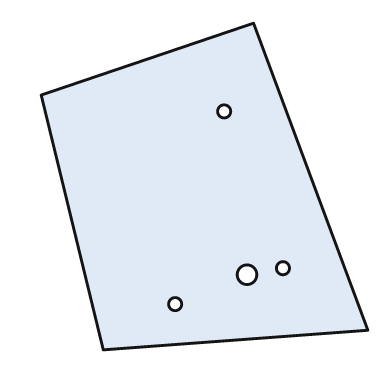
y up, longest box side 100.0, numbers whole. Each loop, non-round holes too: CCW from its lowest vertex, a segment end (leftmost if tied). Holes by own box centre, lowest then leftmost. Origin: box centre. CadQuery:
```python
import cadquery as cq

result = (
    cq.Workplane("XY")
    .moveTo(-31.0, -50.0)
    .lineTo(50.0, -44.0)
    .lineTo(15.0, 50.0)
    .lineTo(-50.0, 28.0)
    .close()
    .moveTo(-9.0, -36.0)
    .circle(2.0)
    .moveTo(13.0, -27.0)
    .circle(3.0)
    .moveTo(24.0, -25.0)
    .circle(2.0)
    .moveTo(6.0, 23.0)
    .circle(2.0)
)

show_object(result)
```